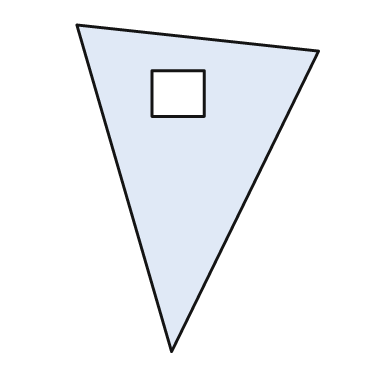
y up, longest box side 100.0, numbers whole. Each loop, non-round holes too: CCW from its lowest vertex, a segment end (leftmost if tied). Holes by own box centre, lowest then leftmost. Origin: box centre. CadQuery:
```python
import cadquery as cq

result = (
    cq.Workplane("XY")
    .moveTo(-8.0, -50.0)
    .lineTo(37.0, 42.0)
    .lineTo(-37.0, 50.0)
    .close()
    .moveTo(-14.0, 22.0)
    .lineTo(2.0, 22.0)
    .lineTo(2.0, 36.0)
    .lineTo(-14.0, 36.0)
    .close()
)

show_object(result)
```